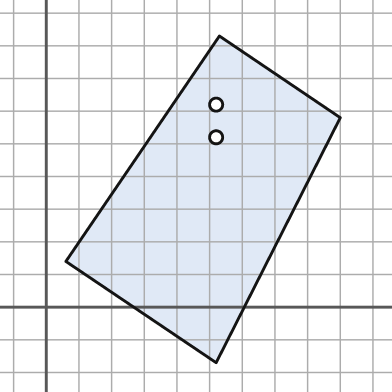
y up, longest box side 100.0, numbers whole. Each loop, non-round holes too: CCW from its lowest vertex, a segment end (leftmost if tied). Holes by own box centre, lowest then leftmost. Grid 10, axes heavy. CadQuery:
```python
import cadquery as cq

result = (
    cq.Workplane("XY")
    .moveTo(52.0, -17.0)
    .lineTo(90.0, 58.0)
    .lineTo(53.0, 83.0)
    .lineTo(6.0, 14.0)
    .close()
    .moveTo(52.0, 52.0)
    .circle(2.0)
    .moveTo(52.0, 62.0)
    .circle(2.0)
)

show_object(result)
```